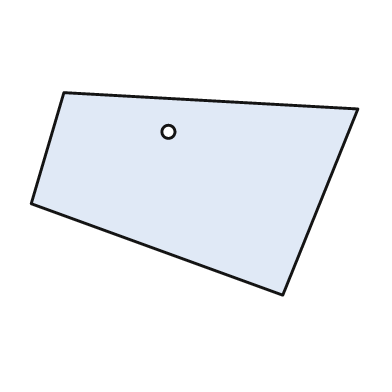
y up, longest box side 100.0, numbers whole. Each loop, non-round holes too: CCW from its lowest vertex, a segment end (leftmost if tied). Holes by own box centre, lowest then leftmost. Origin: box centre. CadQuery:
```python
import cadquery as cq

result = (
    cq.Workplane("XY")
    .moveTo(27.0, -31.0)
    .lineTo(50.0, 26.0)
    .lineTo(-40.0, 31.0)
    .lineTo(-50.0, -3.0)
    .close()
    .moveTo(-8.0, 19.0)
    .circle(2.0)
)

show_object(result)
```